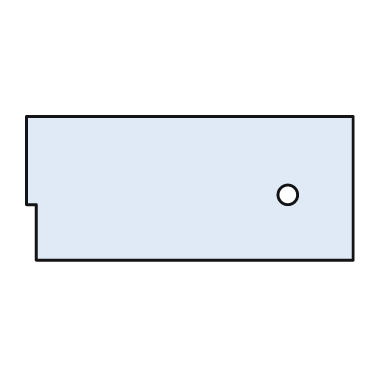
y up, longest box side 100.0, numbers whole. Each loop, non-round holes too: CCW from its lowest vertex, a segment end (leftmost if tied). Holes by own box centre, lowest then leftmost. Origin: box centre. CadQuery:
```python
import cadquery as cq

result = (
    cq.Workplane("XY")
    .moveTo(-47.0, -22.0)
    .lineTo(50.0, -22.0)
    .lineTo(50.0, 22.0)
    .lineTo(-50.0, 22.0)
    .lineTo(-50.0, -5.0)
    .lineTo(-47.0, -5.0)
    .close()
    .moveTo(30.0, -2.0)
    .circle(3.0)
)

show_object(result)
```